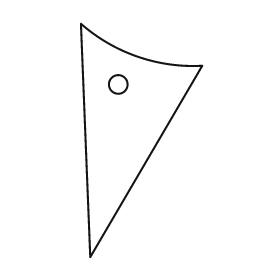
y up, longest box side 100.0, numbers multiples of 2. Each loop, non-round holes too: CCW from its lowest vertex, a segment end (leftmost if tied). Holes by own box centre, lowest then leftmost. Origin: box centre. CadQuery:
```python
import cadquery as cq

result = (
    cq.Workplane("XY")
    .moveTo(-22.0, -50.0)
    .lineTo(26.0, 32.0)
    .threePointArc((-2.0, 36.0), (-26.0, 50.0))
    .close()
    .moveTo(-10.0, 24.0)
    .circle(4.0)
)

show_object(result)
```